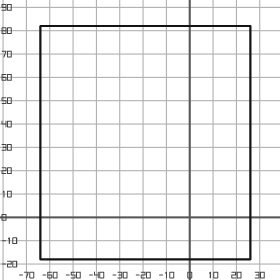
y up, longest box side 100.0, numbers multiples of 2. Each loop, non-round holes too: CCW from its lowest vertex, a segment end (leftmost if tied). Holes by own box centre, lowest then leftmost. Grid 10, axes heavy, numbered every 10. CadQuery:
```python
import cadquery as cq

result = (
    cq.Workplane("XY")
    .moveTo(-64.0, -18.0)
    .lineTo(26.0, -18.0)
    .lineTo(26.0, 82.0)
    .lineTo(-64.0, 82.0)
    .close()
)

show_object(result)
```